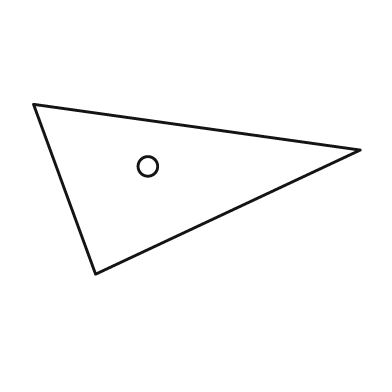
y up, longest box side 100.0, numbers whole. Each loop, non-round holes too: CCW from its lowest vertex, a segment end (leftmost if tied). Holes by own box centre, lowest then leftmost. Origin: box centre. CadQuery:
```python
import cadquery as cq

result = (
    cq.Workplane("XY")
    .moveTo(-31.0, -26.0)
    .lineTo(50.0, 12.0)
    .lineTo(-50.0, 26.0)
    .close()
    .moveTo(-15.0, 7.0)
    .circle(3.0)
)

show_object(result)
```